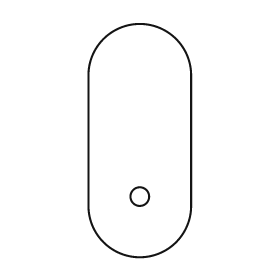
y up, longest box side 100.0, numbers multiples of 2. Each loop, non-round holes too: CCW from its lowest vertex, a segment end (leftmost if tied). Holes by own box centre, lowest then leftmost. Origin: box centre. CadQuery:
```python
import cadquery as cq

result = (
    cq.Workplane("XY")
    .moveTo(-22.0, -28.0)
    .threePointArc((0.0, -50.0), (22.0, -28.0))
    .lineTo(22.0, 28.0)
    .threePointArc((0.0, 50.0), (-22.0, 28.0))
    .close()
    .moveTo(0.0, -24.0)
    .circle(4.0)
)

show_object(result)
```